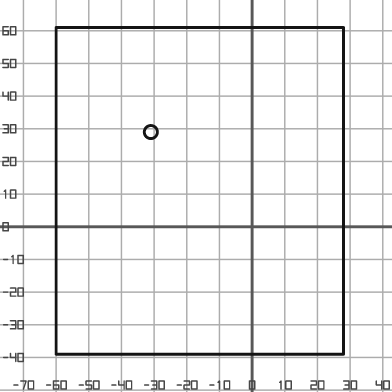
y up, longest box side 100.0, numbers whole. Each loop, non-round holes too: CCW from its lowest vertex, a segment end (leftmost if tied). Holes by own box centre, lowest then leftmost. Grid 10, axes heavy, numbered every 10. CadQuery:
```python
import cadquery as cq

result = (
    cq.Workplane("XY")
    .moveTo(-60.0, -39.0)
    .lineTo(28.0, -39.0)
    .lineTo(28.0, 61.0)
    .lineTo(-60.0, 61.0)
    .close()
    .moveTo(-31.0, 29.0)
    .circle(2.0)
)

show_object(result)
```